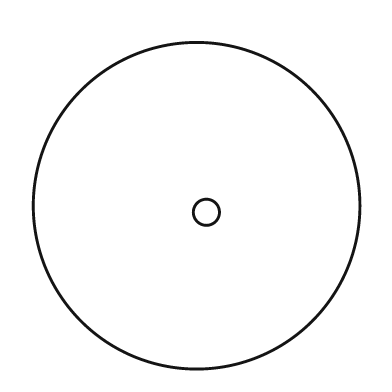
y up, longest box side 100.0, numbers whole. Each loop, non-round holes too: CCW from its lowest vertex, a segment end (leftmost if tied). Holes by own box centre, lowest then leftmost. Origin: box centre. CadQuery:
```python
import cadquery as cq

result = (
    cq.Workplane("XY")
    .moveTo(0.0, 0.0)
    .circle(50.0)
    .moveTo(3.0, -2.0)
    .circle(4.0)
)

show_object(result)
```